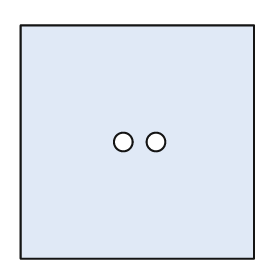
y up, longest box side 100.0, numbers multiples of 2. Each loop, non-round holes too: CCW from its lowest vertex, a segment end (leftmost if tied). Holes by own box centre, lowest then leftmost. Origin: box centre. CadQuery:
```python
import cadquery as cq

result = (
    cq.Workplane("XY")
    .moveTo(-50.0, -50.0)
    .lineTo(50.0, -50.0)
    .lineTo(50.0, 50.0)
    .lineTo(-50.0, 50.0)
    .close()
    .moveTo(-6.0, 0.0)
    .circle(4.0)
    .moveTo(8.0, 0.0)
    .circle(4.0)
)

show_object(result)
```